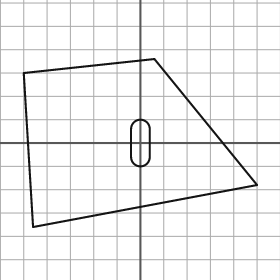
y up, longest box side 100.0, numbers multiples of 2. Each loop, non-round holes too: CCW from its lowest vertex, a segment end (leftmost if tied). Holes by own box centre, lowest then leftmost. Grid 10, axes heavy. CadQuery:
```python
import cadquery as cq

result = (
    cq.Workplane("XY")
    .moveTo(-46.0, -36.0)
    .lineTo(50.0, -18.0)
    .lineTo(6.0, 36.0)
    .lineTo(-50.0, 30.0)
    .close()
    .moveTo(-4.0, -6.0)
    .threePointArc((0.0, -10.0), (4.0, -6.0))
    .lineTo(4.0, 6.0)
    .threePointArc((0.0, 10.0), (-4.0, 6.0))
    .close()
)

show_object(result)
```